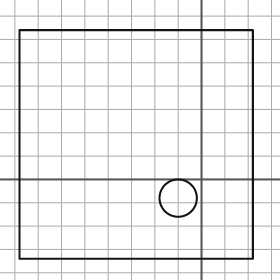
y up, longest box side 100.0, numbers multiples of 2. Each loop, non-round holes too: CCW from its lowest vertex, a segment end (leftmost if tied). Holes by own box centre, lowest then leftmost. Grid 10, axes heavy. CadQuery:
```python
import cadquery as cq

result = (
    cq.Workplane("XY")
    .moveTo(-78.0, -34.0)
    .lineTo(22.0, -34.0)
    .lineTo(22.0, 64.0)
    .lineTo(-78.0, 64.0)
    .close()
    .moveTo(-10.0, -8.0)
    .circle(8.0)
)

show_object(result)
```